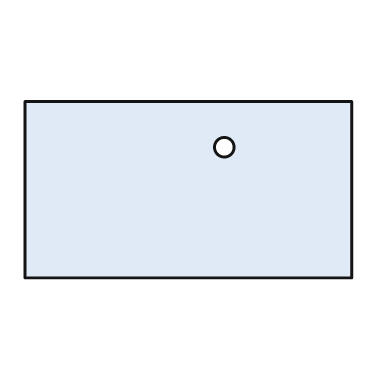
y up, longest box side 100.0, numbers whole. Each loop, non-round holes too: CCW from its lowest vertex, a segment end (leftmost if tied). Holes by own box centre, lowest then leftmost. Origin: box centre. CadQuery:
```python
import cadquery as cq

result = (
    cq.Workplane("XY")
    .moveTo(-50.0, -27.0)
    .lineTo(50.0, -27.0)
    .lineTo(50.0, 27.0)
    .lineTo(-50.0, 27.0)
    .close()
    .moveTo(11.0, 13.0)
    .circle(3.0)
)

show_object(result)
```